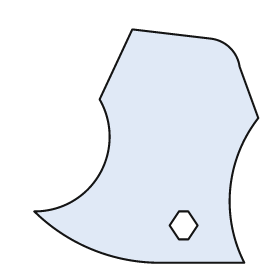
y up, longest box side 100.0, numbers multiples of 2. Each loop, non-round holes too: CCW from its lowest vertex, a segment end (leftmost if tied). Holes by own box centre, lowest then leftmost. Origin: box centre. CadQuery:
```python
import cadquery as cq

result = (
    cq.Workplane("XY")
    .moveTo(4.0, -50.0)
    .lineTo(42.0, -50.0)
    .threePointArc((36.0, -18.0), (48.0, 12.0))
    .lineTo(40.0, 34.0)
    .threePointArc((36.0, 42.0), (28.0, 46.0))
    .lineTo(-6.0, 50.0)
    .lineTo(-20.0, 20.0)
    .threePointArc((-20.0, -12.0), (-48.0, -28.0))
    .threePointArc((-24.0, -44.0), (4.0, -50.0))
    .close()
    .moveTo(14.0, -40.0)
    .lineTo(18.0, -40.0)
    .lineTo(22.0, -34.0)
    .lineTo(18.0, -28.0)
    .lineTo(14.0, -28.0)
    .lineTo(10.0, -34.0)
    .close()
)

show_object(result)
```